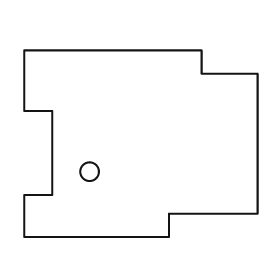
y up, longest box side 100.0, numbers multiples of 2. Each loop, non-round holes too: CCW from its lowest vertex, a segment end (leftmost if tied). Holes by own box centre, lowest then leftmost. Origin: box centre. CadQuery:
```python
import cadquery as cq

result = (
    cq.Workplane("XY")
    .moveTo(-50.0, -40.0)
    .lineTo(12.0, -40.0)
    .lineTo(12.0, -30.0)
    .lineTo(50.0, -30.0)
    .lineTo(50.0, 30.0)
    .lineTo(26.0, 30.0)
    .lineTo(26.0, 40.0)
    .lineTo(-50.0, 40.0)
    .lineTo(-50.0, 14.0)
    .lineTo(-38.0, 14.0)
    .lineTo(-38.0, -22.0)
    .lineTo(-50.0, -22.0)
    .close()
    .moveTo(-22.0, -12.0)
    .circle(4.0)
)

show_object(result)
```